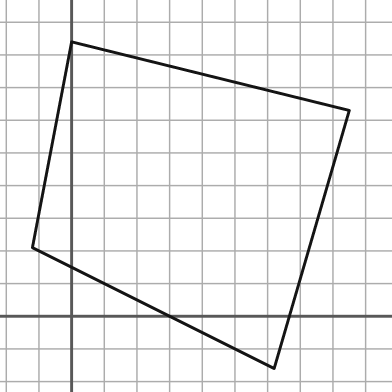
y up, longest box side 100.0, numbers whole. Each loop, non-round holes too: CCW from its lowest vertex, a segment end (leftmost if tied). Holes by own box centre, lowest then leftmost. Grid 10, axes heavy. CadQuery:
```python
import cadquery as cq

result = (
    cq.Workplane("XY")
    .moveTo(62.0, -16.0)
    .lineTo(85.0, 63.0)
    .lineTo(0.0, 84.0)
    .lineTo(-12.0, 21.0)
    .close()
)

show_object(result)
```